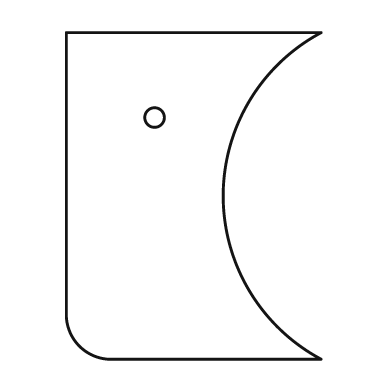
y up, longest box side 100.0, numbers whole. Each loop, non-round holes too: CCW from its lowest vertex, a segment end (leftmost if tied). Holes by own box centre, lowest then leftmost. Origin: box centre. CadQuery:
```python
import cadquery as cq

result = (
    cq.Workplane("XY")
    .moveTo(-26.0, -50.0)
    .lineTo(39.0, -50.0)
    .threePointArc((9.0, 0.0), (39.0, 50.0))
    .lineTo(-39.0, 50.0)
    .lineTo(-39.0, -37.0)
    .threePointArc((-35.0, -46.0), (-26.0, -50.0))
    .close()
    .moveTo(-12.0, 24.0)
    .circle(3.0)
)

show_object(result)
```